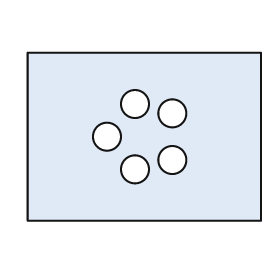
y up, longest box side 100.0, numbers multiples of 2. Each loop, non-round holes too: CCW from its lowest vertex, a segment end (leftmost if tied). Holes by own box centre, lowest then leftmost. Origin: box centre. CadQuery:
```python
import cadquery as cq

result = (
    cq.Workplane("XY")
    .moveTo(-50.0, -36.0)
    .lineTo(50.0, -36.0)
    .lineTo(50.0, 36.0)
    .lineTo(-50.0, 36.0)
    .close()
    .moveTo(-4.0, -14.0)
    .circle(6.0)
    .moveTo(12.0, -10.0)
    .circle(6.0)
    .moveTo(-16.0, 0.0)
    .circle(6.0)
    .moveTo(12.0, 10.0)
    .circle(6.0)
    .moveTo(-4.0, 14.0)
    .circle(6.0)
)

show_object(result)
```